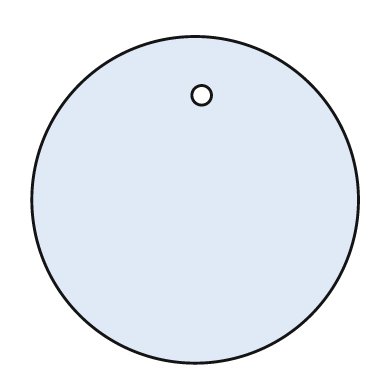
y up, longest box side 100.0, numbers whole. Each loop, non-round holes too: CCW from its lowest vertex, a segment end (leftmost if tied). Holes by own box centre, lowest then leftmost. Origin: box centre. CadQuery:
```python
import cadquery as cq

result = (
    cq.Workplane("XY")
    .moveTo(0.0, 0.0)
    .circle(50.0)
    .moveTo(2.0, 32.0)
    .circle(3.0)
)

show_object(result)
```